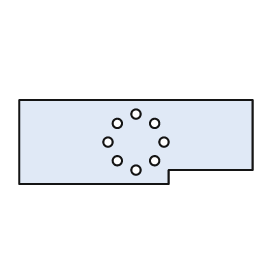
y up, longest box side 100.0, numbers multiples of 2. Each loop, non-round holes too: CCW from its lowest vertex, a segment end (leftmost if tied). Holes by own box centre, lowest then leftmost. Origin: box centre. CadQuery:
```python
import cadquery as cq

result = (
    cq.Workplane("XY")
    .moveTo(-50.0, -18.0)
    .lineTo(14.0, -18.0)
    .lineTo(14.0, -12.0)
    .lineTo(50.0, -12.0)
    .lineTo(50.0, 18.0)
    .lineTo(-50.0, 18.0)
    .close()
    .moveTo(0.0, -12.0)
    .circle(2.0)
    .moveTo(-8.0, -8.0)
    .circle(2.0)
    .moveTo(8.0, -8.0)
    .circle(2.0)
    .moveTo(-12.0, 0.0)
    .circle(2.0)
    .moveTo(12.0, 0.0)
    .circle(2.0)
    .moveTo(-8.0, 8.0)
    .circle(2.0)
    .moveTo(8.0, 8.0)
    .circle(2.0)
    .moveTo(0.0, 12.0)
    .circle(2.0)
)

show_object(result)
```